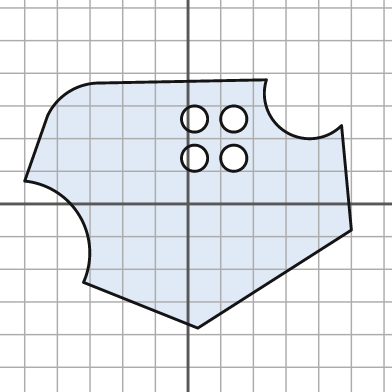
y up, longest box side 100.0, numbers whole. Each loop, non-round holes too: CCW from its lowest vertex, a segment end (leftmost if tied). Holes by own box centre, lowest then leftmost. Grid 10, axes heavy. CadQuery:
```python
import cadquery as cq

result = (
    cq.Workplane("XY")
    .moveTo(3.0, -38.0)
    .lineTo(50.0, -8.0)
    .lineTo(47.0, 24.0)
    .threePointArc((30.0, 22.0), (24.0, 38.0))
    .lineTo(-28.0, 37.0)
    .threePointArc((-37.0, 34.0), (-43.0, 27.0))
    .lineTo(-50.0, 7.0)
    .threePointArc((-33.0, -4.0), (-32.0, -24.0))
    .close()
    .moveTo(2.0, 14.0)
    .circle(4.0)
    .moveTo(14.0, 14.0)
    .circle(4.0)
    .moveTo(2.0, 26.0)
    .circle(4.0)
    .moveTo(14.0, 26.0)
    .circle(4.0)
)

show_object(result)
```